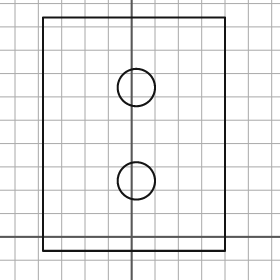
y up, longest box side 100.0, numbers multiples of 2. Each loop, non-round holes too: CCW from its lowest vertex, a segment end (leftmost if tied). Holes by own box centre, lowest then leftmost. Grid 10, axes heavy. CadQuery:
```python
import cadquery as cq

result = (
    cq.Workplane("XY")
    .moveTo(-38.0, -6.0)
    .lineTo(40.0, -6.0)
    .lineTo(40.0, 94.0)
    .lineTo(-38.0, 94.0)
    .close()
    .moveTo(2.0, 24.0)
    .circle(8.0)
    .moveTo(2.0, 64.0)
    .circle(8.0)
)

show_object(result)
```